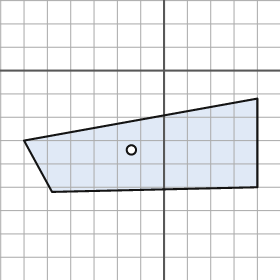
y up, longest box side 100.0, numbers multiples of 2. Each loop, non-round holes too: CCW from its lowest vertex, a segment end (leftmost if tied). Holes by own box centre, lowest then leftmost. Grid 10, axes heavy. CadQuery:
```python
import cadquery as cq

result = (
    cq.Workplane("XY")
    .moveTo(-48.0, -52.0)
    .lineTo(40.0, -50.0)
    .lineTo(40.0, -12.0)
    .lineTo(-60.0, -30.0)
    .close()
    .moveTo(-14.0, -34.0)
    .circle(2.0)
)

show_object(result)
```